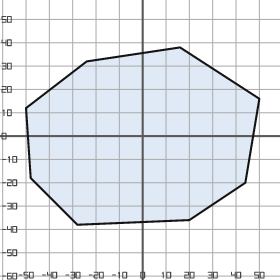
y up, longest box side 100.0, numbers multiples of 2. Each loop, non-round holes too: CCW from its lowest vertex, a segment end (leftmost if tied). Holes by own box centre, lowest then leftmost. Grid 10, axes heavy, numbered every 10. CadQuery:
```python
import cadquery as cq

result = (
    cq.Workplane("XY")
    .moveTo(-28.0, -38.0)
    .lineTo(20.0, -36.0)
    .lineTo(44.0, -20.0)
    .lineTo(50.0, 16.0)
    .lineTo(16.0, 38.0)
    .lineTo(-24.0, 32.0)
    .lineTo(-50.0, 12.0)
    .lineTo(-48.0, -18.0)
    .close()
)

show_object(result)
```